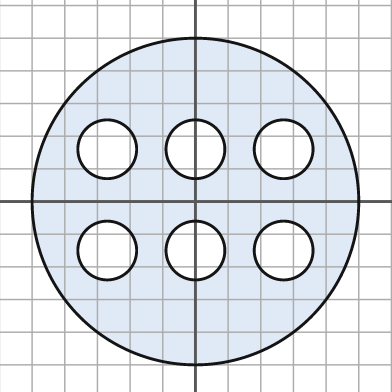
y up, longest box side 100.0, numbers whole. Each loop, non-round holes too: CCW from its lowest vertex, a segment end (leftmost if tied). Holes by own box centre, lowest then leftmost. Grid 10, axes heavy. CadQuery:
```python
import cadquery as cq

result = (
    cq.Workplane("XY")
    .moveTo(0.0, 0.0)
    .circle(50.0)
    .moveTo(-27.0, -15.0)
    .circle(9.0)
    .moveTo(0.0, -15.0)
    .circle(9.0)
    .moveTo(27.0, -15.0)
    .circle(9.0)
    .moveTo(-27.0, 16.0)
    .circle(9.0)
    .moveTo(0.0, 16.0)
    .circle(9.0)
    .moveTo(27.0, 16.0)
    .circle(9.0)
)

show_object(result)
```